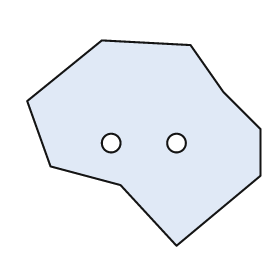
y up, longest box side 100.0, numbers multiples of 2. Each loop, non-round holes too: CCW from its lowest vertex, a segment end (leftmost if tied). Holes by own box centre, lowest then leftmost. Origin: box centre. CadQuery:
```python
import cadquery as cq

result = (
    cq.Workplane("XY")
    .moveTo(14.0, -44.0)
    .lineTo(50.0, -14.0)
    .lineTo(50.0, 6.0)
    .lineTo(34.0, 22.0)
    .lineTo(20.0, 42.0)
    .lineTo(-18.0, 44.0)
    .lineTo(-50.0, 18.0)
    .lineTo(-40.0, -10.0)
    .lineTo(-10.0, -18.0)
    .close()
    .moveTo(-14.0, 0.0)
    .circle(4.0)
    .moveTo(14.0, 0.0)
    .circle(4.0)
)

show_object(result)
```